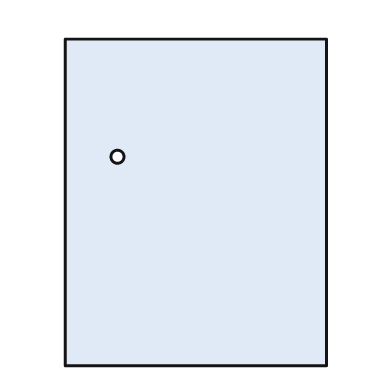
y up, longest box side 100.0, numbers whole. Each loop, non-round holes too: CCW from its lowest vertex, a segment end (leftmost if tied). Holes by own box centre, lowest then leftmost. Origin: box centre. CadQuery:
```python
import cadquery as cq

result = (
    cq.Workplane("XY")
    .moveTo(-40.0, -50.0)
    .lineTo(40.0, -50.0)
    .lineTo(40.0, 50.0)
    .lineTo(-40.0, 50.0)
    .close()
    .moveTo(-24.0, 14.0)
    .circle(2.0)
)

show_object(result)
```